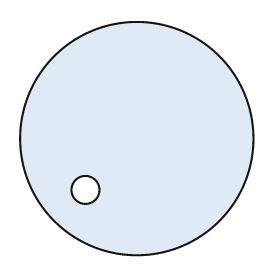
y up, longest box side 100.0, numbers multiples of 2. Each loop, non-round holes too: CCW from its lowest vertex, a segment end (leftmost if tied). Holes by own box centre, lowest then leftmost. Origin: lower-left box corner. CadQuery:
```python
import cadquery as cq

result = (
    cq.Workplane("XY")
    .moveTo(50.0, 50.0)
    .circle(50.0)
    .moveTo(28.0, 28.0)
    .circle(6.0)
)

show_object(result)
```